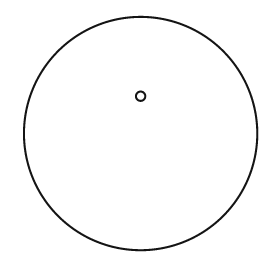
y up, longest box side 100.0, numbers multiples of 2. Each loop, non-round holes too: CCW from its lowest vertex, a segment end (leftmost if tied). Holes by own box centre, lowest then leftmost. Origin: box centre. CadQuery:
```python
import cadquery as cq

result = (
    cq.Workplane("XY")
    .moveTo(0.0, 0.0)
    .circle(50.0)
    .moveTo(0.0, 16.0)
    .circle(2.0)
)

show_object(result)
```